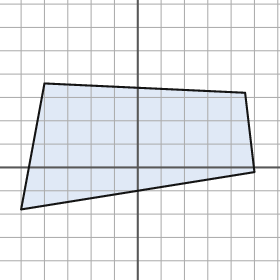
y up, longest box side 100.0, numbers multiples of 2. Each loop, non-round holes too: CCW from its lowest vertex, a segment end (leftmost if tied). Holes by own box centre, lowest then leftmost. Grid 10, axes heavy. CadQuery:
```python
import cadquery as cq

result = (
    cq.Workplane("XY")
    .moveTo(-50.0, -18.0)
    .lineTo(50.0, -2.0)
    .lineTo(46.0, 32.0)
    .lineTo(-40.0, 36.0)
    .close()
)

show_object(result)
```